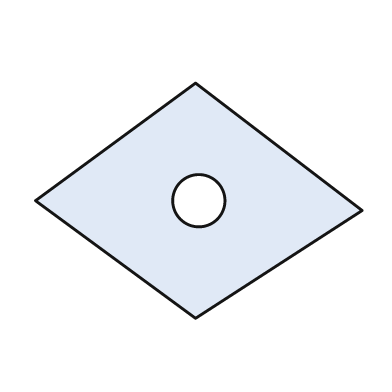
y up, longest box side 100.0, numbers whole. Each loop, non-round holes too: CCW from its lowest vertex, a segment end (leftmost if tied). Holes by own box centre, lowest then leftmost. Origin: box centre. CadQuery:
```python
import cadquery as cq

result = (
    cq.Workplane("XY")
    .moveTo(-1.0, -36.0)
    .lineTo(50.0, -3.0)
    .lineTo(-1.0, 36.0)
    .lineTo(-50.0, 0.0)
    .close()
    .moveTo(0.0, 0.0)
    .circle(8.0)
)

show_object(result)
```